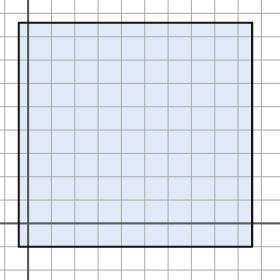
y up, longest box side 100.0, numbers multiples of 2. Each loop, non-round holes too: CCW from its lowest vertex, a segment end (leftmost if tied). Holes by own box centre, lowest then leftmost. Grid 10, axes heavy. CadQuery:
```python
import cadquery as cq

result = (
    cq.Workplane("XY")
    .moveTo(-4.0, -10.0)
    .lineTo(96.0, -10.0)
    .lineTo(96.0, 86.0)
    .lineTo(-4.0, 86.0)
    .close()
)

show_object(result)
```